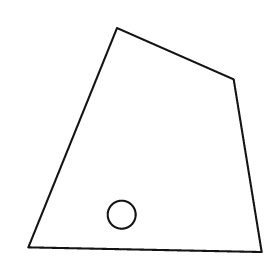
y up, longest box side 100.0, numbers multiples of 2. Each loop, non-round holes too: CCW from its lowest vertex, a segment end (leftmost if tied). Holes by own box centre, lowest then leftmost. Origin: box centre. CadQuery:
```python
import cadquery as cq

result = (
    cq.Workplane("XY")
    .moveTo(50.0, -48.0)
    .lineTo(38.0, 26.0)
    .lineTo(-12.0, 48.0)
    .lineTo(-50.0, -46.0)
    .close()
    .moveTo(-10.0, -32.0)
    .circle(6.0)
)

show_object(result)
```